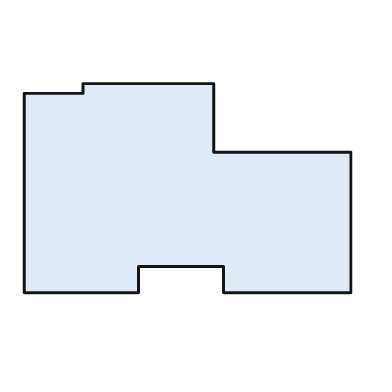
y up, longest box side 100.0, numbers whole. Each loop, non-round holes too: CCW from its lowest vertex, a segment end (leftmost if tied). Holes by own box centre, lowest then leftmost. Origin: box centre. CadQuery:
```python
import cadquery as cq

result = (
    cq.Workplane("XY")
    .moveTo(-50.0, -32.0)
    .lineTo(-15.0, -32.0)
    .lineTo(-15.0, -24.0)
    .lineTo(11.0, -24.0)
    .lineTo(11.0, -32.0)
    .lineTo(50.0, -32.0)
    .lineTo(50.0, 11.0)
    .lineTo(8.0, 11.0)
    .lineTo(8.0, 32.0)
    .lineTo(-32.0, 32.0)
    .lineTo(-32.0, 29.0)
    .lineTo(-50.0, 29.0)
    .close()
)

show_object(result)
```